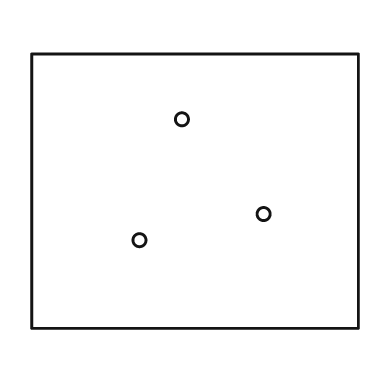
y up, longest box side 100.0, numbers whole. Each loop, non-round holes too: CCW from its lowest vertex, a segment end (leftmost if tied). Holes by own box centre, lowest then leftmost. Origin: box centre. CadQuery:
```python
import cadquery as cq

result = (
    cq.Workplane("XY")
    .moveTo(-50.0, -42.0)
    .lineTo(50.0, -42.0)
    .lineTo(50.0, 42.0)
    .lineTo(-50.0, 42.0)
    .close()
    .moveTo(-17.0, -15.0)
    .circle(2.0)
    .moveTo(21.0, -7.0)
    .circle(2.0)
    .moveTo(-4.0, 22.0)
    .circle(2.0)
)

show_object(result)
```